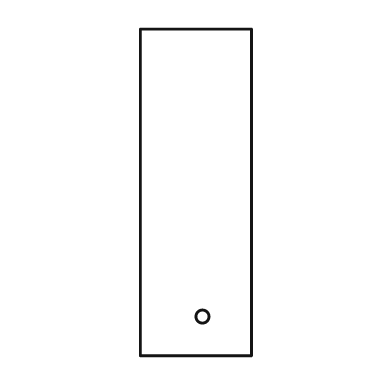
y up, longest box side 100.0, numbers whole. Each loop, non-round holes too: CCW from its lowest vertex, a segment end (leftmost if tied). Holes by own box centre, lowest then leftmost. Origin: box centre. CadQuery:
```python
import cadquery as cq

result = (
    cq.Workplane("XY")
    .moveTo(-17.0, -50.0)
    .lineTo(17.0, -50.0)
    .lineTo(17.0, 50.0)
    .lineTo(-17.0, 50.0)
    .close()
    .moveTo(2.0, -38.0)
    .circle(2.0)
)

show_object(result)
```